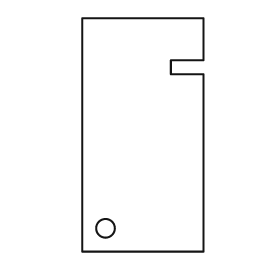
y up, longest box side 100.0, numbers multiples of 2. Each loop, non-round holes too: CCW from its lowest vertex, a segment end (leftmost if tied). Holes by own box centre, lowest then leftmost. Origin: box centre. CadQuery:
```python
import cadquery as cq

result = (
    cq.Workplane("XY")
    .moveTo(-26.0, -50.0)
    .lineTo(26.0, -50.0)
    .lineTo(26.0, 26.0)
    .lineTo(12.0, 26.0)
    .lineTo(12.0, 32.0)
    .lineTo(26.0, 32.0)
    .lineTo(26.0, 50.0)
    .lineTo(-26.0, 50.0)
    .close()
    .moveTo(-16.0, -40.0)
    .circle(4.0)
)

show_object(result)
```